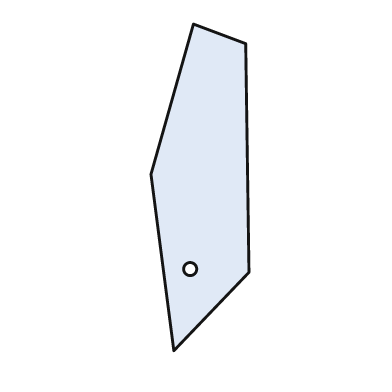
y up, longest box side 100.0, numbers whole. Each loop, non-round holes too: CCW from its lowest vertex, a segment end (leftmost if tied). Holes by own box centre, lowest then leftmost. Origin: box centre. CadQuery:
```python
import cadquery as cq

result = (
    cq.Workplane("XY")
    .moveTo(-8.0, -50.0)
    .lineTo(15.0, -26.0)
    .lineTo(14.0, 44.0)
    .lineTo(-2.0, 50.0)
    .lineTo(-15.0, 4.0)
    .close()
    .moveTo(-3.0, -25.0)
    .circle(2.0)
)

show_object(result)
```